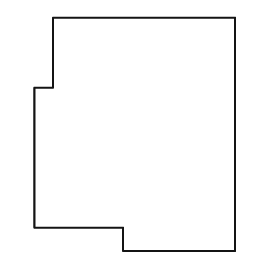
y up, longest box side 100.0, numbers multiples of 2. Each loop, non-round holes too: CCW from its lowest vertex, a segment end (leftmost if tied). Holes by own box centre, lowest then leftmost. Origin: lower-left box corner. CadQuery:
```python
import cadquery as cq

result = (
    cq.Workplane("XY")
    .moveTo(38.0, 0.0)
    .lineTo(86.0, 0.0)
    .lineTo(86.0, 100.0)
    .lineTo(8.0, 100.0)
    .lineTo(8.0, 70.0)
    .lineTo(0.0, 70.0)
    .lineTo(0.0, 10.0)
    .lineTo(38.0, 10.0)
    .close()
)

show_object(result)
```